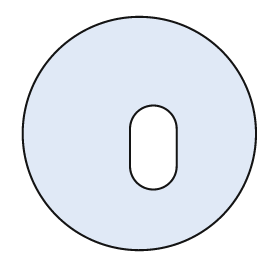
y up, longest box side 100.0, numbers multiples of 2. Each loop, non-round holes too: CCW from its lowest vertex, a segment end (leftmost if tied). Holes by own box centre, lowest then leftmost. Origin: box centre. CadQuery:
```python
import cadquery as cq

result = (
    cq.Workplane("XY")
    .moveTo(0.0, 0.0)
    .circle(50.0)
    .moveTo(-4.0, -14.0)
    .threePointArc((6.0, -24.0), (16.0, -14.0))
    .lineTo(16.0, 2.0)
    .threePointArc((6.0, 12.0), (-4.0, 2.0))
    .close()
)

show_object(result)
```